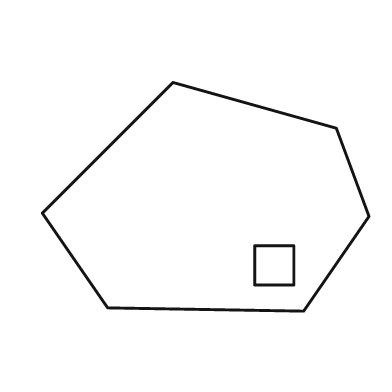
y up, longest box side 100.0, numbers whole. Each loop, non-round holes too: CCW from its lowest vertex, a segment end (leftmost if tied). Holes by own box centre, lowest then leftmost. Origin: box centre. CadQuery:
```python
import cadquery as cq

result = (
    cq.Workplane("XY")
    .moveTo(30.0, -35.0)
    .lineTo(50.0, -6.0)
    .lineTo(40.0, 21.0)
    .lineTo(-10.0, 35.0)
    .lineTo(-50.0, -5.0)
    .lineTo(-30.0, -34.0)
    .close()
    .moveTo(15.0, -27.0)
    .lineTo(27.0, -27.0)
    .lineTo(27.0, -15.0)
    .lineTo(15.0, -15.0)
    .close()
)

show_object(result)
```